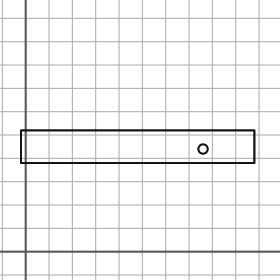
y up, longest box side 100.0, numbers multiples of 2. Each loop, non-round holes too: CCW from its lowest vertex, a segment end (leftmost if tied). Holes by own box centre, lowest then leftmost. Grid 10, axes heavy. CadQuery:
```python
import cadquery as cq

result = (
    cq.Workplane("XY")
    .moveTo(-2.0, 38.0)
    .lineTo(98.0, 38.0)
    .lineTo(98.0, 52.0)
    .lineTo(-2.0, 52.0)
    .close()
    .moveTo(76.0, 44.0)
    .circle(2.0)
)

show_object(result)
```